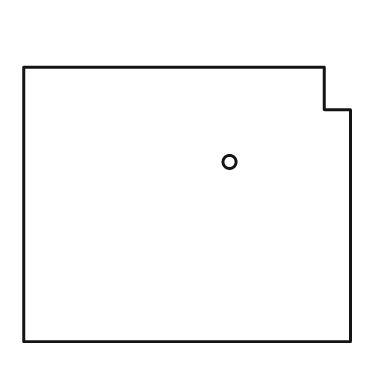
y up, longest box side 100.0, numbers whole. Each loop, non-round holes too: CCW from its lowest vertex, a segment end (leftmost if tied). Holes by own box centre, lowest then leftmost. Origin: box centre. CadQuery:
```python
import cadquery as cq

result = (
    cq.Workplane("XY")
    .moveTo(-50.0, -42.0)
    .lineTo(50.0, -42.0)
    .lineTo(50.0, 29.0)
    .lineTo(42.0, 29.0)
    .lineTo(42.0, 42.0)
    .lineTo(-50.0, 42.0)
    .close()
    .moveTo(13.0, 13.0)
    .circle(2.0)
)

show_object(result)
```